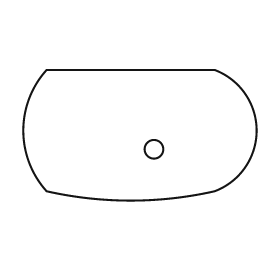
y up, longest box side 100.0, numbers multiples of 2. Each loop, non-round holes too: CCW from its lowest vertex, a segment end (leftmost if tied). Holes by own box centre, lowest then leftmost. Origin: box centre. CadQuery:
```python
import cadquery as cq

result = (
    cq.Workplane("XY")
    .moveTo(-40.0, -24.0)
    .threePointArc((-4.0, -28.0), (32.0, -24.0))
    .threePointArc((50.0, 2.0), (32.0, 28.0))
    .lineTo(-40.0, 28.0)
    .threePointArc((-50.0, 2.0), (-40.0, -24.0))
    .close()
    .moveTo(6.0, -6.0)
    .circle(4.0)
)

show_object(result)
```